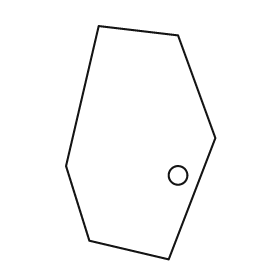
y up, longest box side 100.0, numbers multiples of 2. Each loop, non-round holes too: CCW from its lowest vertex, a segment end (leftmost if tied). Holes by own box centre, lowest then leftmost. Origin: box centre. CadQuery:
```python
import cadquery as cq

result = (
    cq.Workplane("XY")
    .moveTo(12.0, -50.0)
    .lineTo(32.0, 2.0)
    .lineTo(16.0, 46.0)
    .lineTo(-18.0, 50.0)
    .lineTo(-32.0, -10.0)
    .lineTo(-22.0, -42.0)
    .close()
    .moveTo(16.0, -14.0)
    .circle(4.0)
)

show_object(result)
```